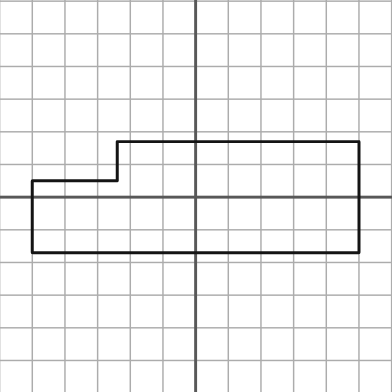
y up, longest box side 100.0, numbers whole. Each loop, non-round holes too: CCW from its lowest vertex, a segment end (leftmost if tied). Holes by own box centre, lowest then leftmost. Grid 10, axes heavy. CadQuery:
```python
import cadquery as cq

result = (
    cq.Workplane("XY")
    .moveTo(-50.0, -17.0)
    .lineTo(50.0, -17.0)
    .lineTo(50.0, 17.0)
    .lineTo(-24.0, 17.0)
    .lineTo(-24.0, 5.0)
    .lineTo(-50.0, 5.0)
    .close()
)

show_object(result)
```